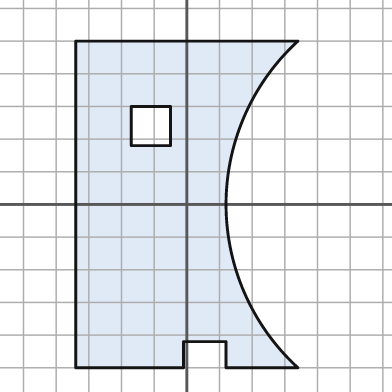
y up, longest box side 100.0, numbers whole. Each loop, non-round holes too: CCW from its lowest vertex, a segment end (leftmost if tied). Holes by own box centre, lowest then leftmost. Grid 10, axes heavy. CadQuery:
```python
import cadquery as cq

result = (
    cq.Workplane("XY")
    .moveTo(-34.0, -50.0)
    .lineTo(-1.0, -50.0)
    .lineTo(-1.0, -42.0)
    .lineTo(12.0, -42.0)
    .lineTo(12.0, -50.0)
    .lineTo(34.0, -50.0)
    .threePointArc((12.0, 0.0), (34.0, 50.0))
    .lineTo(-34.0, 50.0)
    .close()
    .moveTo(-17.0, 18.0)
    .lineTo(-5.0, 18.0)
    .lineTo(-5.0, 30.0)
    .lineTo(-17.0, 30.0)
    .close()
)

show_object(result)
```